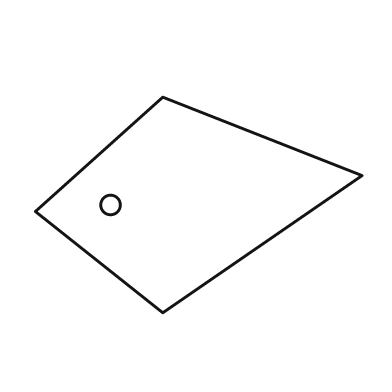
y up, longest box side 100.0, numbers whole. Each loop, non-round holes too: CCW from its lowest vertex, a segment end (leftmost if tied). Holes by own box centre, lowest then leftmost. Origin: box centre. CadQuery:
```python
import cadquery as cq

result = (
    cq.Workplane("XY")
    .moveTo(-11.0, -33.0)
    .lineTo(50.0, 9.0)
    .lineTo(-11.0, 33.0)
    .lineTo(-50.0, -2.0)
    .close()
    .moveTo(-27.0, 0.0)
    .circle(3.0)
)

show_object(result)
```